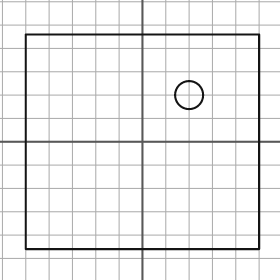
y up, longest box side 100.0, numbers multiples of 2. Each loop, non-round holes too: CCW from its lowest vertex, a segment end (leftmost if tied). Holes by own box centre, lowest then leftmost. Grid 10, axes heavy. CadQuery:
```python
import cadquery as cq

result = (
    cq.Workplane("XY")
    .moveTo(-50.0, -46.0)
    .lineTo(50.0, -46.0)
    .lineTo(50.0, 46.0)
    .lineTo(-50.0, 46.0)
    .close()
    .moveTo(20.0, 20.0)
    .circle(6.0)
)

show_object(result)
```